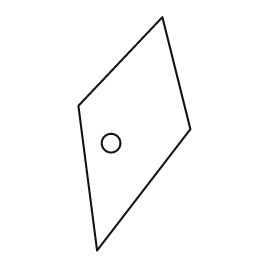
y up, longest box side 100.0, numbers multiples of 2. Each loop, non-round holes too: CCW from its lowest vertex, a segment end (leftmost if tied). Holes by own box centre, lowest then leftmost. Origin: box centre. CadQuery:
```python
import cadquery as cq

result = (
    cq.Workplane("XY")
    .moveTo(-16.0, -50.0)
    .lineTo(24.0, 2.0)
    .lineTo(12.0, 50.0)
    .lineTo(-24.0, 12.0)
    .close()
    .moveTo(-10.0, -4.0)
    .circle(4.0)
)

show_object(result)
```